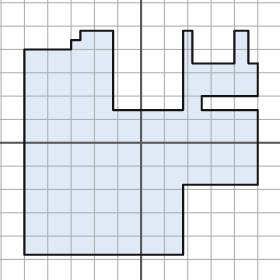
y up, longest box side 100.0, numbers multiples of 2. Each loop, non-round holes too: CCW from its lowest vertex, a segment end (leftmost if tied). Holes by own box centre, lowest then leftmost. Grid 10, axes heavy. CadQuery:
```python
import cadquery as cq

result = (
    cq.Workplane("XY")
    .moveTo(-50.0, -48.0)
    .lineTo(18.0, -48.0)
    .lineTo(18.0, -18.0)
    .lineTo(50.0, -18.0)
    .lineTo(50.0, 14.0)
    .lineTo(26.0, 14.0)
    .lineTo(26.0, 20.0)
    .lineTo(50.0, 20.0)
    .lineTo(50.0, 34.0)
    .lineTo(46.0, 34.0)
    .lineTo(46.0, 48.0)
    .lineTo(40.0, 48.0)
    .lineTo(40.0, 34.0)
    .lineTo(22.0, 34.0)
    .lineTo(22.0, 48.0)
    .lineTo(18.0, 48.0)
    .lineTo(18.0, 14.0)
    .lineTo(-12.0, 14.0)
    .lineTo(-12.0, 48.0)
    .lineTo(-26.0, 48.0)
    .lineTo(-26.0, 44.0)
    .lineTo(-30.0, 44.0)
    .lineTo(-30.0, 40.0)
    .lineTo(-50.0, 40.0)
    .close()
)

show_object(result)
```